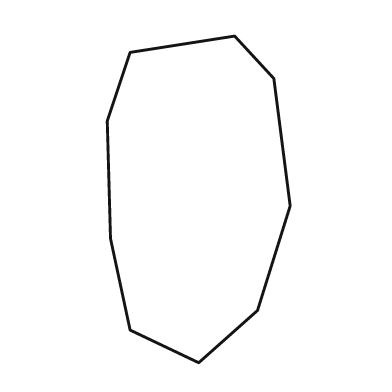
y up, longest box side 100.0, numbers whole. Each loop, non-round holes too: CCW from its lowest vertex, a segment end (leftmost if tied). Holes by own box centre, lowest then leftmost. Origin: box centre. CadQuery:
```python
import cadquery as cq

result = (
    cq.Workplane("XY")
    .moveTo(0.0, -50.0)
    .lineTo(18.0, -34.0)
    .lineTo(28.0, -2.0)
    .lineTo(23.0, 37.0)
    .lineTo(11.0, 50.0)
    .lineTo(-21.0, 45.0)
    .lineTo(-28.0, 24.0)
    .lineTo(-27.0, -12.0)
    .lineTo(-21.0, -40.0)
    .close()
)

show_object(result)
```